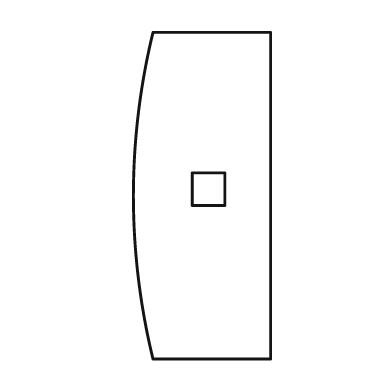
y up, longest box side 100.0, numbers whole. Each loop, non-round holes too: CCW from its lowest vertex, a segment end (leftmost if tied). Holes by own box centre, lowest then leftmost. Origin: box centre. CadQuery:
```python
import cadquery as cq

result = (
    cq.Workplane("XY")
    .moveTo(-15.0, -50.0)
    .lineTo(21.0, -50.0)
    .lineTo(21.0, 50.0)
    .lineTo(-15.0, 50.0)
    .threePointArc((-21.0, 0.0), (-15.0, -50.0))
    .close()
    .moveTo(-3.0, -3.0)
    .lineTo(7.0, -3.0)
    .lineTo(7.0, 7.0)
    .lineTo(-3.0, 7.0)
    .close()
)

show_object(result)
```